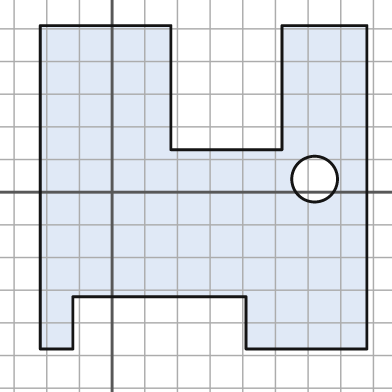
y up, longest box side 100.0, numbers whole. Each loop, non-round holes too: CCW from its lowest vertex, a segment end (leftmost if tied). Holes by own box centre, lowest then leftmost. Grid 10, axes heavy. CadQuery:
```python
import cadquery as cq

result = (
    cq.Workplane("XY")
    .moveTo(-22.0, -48.0)
    .lineTo(-12.0, -48.0)
    .lineTo(-12.0, -32.0)
    .lineTo(41.0, -32.0)
    .lineTo(41.0, -48.0)
    .lineTo(78.0, -48.0)
    .lineTo(78.0, 51.0)
    .lineTo(52.0, 51.0)
    .lineTo(52.0, 13.0)
    .lineTo(18.0, 13.0)
    .lineTo(18.0, 51.0)
    .lineTo(-22.0, 51.0)
    .close()
    .moveTo(62.0, 4.0)
    .circle(7.0)
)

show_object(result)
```